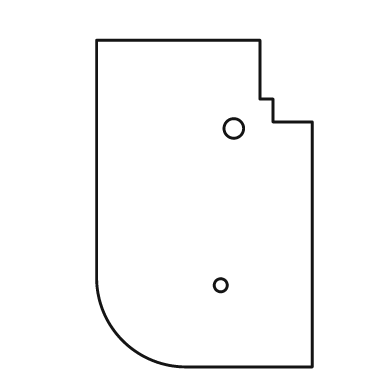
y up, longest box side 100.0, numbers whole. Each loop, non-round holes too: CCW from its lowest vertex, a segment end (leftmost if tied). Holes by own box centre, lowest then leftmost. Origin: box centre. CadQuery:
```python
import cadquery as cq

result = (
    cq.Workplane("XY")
    .moveTo(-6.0, -50.0)
    .lineTo(33.0, -50.0)
    .lineTo(33.0, 25.0)
    .lineTo(21.0, 25.0)
    .lineTo(21.0, 32.0)
    .lineTo(17.0, 32.0)
    .lineTo(17.0, 50.0)
    .lineTo(-33.0, 50.0)
    .lineTo(-33.0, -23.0)
    .threePointArc((-25.0, -42.0), (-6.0, -50.0))
    .close()
    .moveTo(5.0, -25.0)
    .circle(2.0)
    .moveTo(9.0, 23.0)
    .circle(3.0)
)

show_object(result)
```